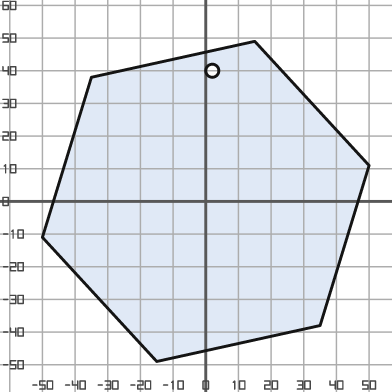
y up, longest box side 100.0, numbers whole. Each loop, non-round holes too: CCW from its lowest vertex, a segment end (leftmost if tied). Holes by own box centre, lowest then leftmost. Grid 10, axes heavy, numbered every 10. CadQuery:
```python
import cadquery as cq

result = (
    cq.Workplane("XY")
    .moveTo(-15.0, -49.0)
    .lineTo(35.0, -38.0)
    .lineTo(50.0, 11.0)
    .lineTo(15.0, 49.0)
    .lineTo(-35.0, 38.0)
    .lineTo(-50.0, -11.0)
    .close()
    .moveTo(2.0, 40.0)
    .circle(2.0)
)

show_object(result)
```